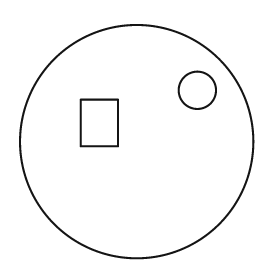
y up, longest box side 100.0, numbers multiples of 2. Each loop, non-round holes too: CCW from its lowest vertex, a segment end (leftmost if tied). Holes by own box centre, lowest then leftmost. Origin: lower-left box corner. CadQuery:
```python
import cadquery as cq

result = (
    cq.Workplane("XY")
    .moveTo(50.0, 50.0)
    .circle(50.0)
    .moveTo(26.0, 48.0)
    .lineTo(42.0, 48.0)
    .lineTo(42.0, 68.0)
    .lineTo(26.0, 68.0)
    .close()
    .moveTo(76.0, 72.0)
    .circle(8.0)
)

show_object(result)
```